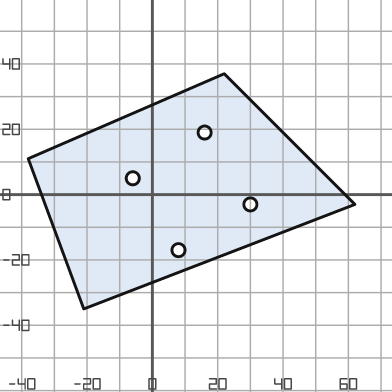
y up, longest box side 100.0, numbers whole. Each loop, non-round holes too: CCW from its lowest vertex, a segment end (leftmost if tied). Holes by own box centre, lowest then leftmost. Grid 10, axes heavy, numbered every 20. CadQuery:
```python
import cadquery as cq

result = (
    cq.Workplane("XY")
    .moveTo(-21.0, -35.0)
    .lineTo(62.0, -3.0)
    .lineTo(22.0, 37.0)
    .lineTo(-38.0, 11.0)
    .close()
    .moveTo(8.0, -17.0)
    .circle(2.0)
    .moveTo(30.0, -3.0)
    .circle(2.0)
    .moveTo(-6.0, 5.0)
    .circle(2.0)
    .moveTo(16.0, 19.0)
    .circle(2.0)
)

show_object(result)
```